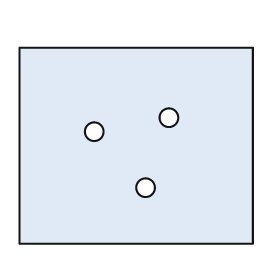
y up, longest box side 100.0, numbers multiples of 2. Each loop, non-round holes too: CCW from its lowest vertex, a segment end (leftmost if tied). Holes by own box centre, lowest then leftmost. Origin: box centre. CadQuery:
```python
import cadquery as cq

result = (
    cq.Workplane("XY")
    .moveTo(-50.0, -42.0)
    .lineTo(50.0, -42.0)
    .lineTo(50.0, 42.0)
    .lineTo(-50.0, 42.0)
    .close()
    .moveTo(4.0, -18.0)
    .circle(4.0)
    .moveTo(-18.0, 6.0)
    .circle(4.0)
    .moveTo(14.0, 12.0)
    .circle(4.0)
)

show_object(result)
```